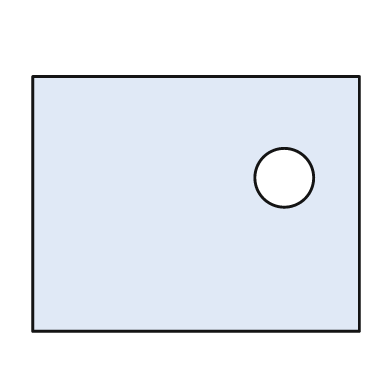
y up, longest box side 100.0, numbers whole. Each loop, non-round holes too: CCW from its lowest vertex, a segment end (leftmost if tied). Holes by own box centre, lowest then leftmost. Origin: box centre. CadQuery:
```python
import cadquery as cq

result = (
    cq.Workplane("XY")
    .moveTo(-50.0, -39.0)
    .lineTo(50.0, -39.0)
    .lineTo(50.0, 39.0)
    .lineTo(-50.0, 39.0)
    .close()
    .moveTo(27.0, 8.0)
    .circle(9.0)
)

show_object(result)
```